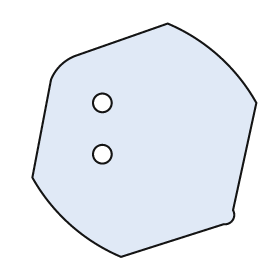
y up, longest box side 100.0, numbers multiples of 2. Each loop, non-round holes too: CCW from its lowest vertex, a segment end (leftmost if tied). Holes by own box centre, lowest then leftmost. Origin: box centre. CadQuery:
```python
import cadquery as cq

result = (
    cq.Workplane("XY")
    .moveTo(-10.0, -50.0)
    .lineTo(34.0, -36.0)
    .threePointArc((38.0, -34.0), (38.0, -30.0))
    .lineTo(48.0, 16.0)
    .threePointArc((32.0, 36.0), (10.0, 50.0))
    .lineTo(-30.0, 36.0)
    .threePointArc((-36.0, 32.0), (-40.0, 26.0))
    .lineTo(-48.0, -16.0)
    .threePointArc((-32.0, -36.0), (-10.0, -50.0))
    .close()
    .moveTo(-18.0, -6.0)
    .circle(4.0)
    .moveTo(-18.0, 16.0)
    .circle(4.0)
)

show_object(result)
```